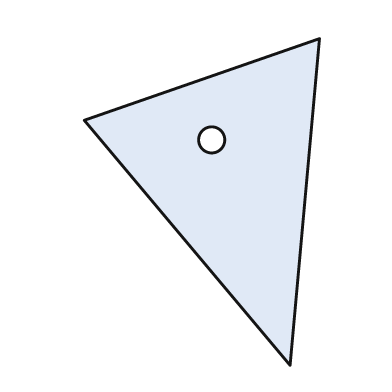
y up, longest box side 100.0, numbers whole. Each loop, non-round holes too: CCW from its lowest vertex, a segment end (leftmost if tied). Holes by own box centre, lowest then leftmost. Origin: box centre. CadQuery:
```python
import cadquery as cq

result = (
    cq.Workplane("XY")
    .moveTo(27.0, -50.0)
    .lineTo(36.0, 50.0)
    .lineTo(-36.0, 25.0)
    .close()
    .moveTo(3.0, 19.0)
    .circle(4.0)
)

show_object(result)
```